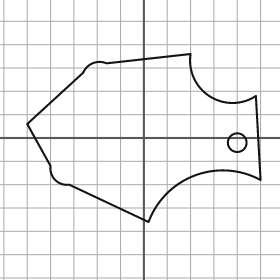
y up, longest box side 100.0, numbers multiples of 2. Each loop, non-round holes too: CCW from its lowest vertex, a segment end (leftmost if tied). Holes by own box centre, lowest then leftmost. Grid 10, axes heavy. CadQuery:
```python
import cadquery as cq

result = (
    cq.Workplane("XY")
    .moveTo(2.0, -36.0)
    .threePointArc((22.0, -16.0), (50.0, -18.0))
    .lineTo(48.0, 18.0)
    .threePointArc((28.0, 18.0), (20.0, 36.0))
    .lineTo(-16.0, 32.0)
    .threePointArc((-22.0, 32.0), (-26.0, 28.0))
    .lineTo(-50.0, 6.0)
    .lineTo(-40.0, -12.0)
    .threePointArc((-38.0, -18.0), (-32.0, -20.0))
    .close()
    .moveTo(40.0, -2.0)
    .circle(4.0)
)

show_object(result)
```